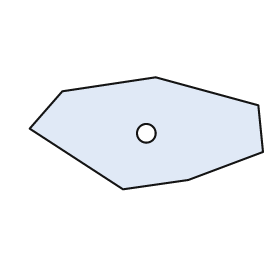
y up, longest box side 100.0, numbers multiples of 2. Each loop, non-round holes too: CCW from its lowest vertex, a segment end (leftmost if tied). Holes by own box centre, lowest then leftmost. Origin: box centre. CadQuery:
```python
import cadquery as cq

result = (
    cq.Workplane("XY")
    .moveTo(-10.0, -24.0)
    .lineTo(18.0, -20.0)
    .lineTo(50.0, -8.0)
    .lineTo(48.0, 12.0)
    .lineTo(4.0, 24.0)
    .lineTo(-36.0, 18.0)
    .lineTo(-50.0, 2.0)
    .close()
    .moveTo(0.0, 0.0)
    .circle(4.0)
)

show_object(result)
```